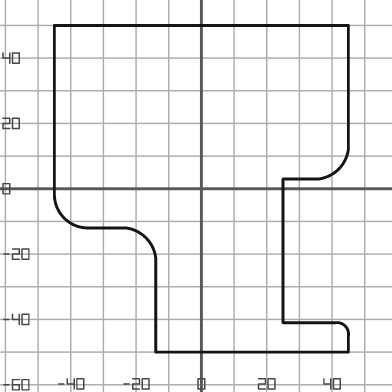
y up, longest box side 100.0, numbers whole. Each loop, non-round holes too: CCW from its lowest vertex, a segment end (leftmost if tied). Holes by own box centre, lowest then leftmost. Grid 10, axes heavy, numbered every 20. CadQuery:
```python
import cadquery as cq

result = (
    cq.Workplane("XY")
    .moveTo(-14.0, -50.0)
    .lineTo(45.0, -50.0)
    .lineTo(45.0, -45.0)
    .threePointArc((44.0, -42.0), (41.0, -41.0))
    .lineTo(25.0, -41.0)
    .lineTo(25.0, 3.0)
    .lineTo(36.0, 3.0)
    .threePointArc((42.0, 6.0), (45.0, 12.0))
    .lineTo(45.0, 50.0)
    .lineTo(-45.0, 50.0)
    .lineTo(-45.0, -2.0)
    .threePointArc((-42.0, -9.0), (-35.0, -12.0))
    .lineTo(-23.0, -12.0)
    .threePointArc((-17.0, -15.0), (-14.0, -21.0))
    .close()
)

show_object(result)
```